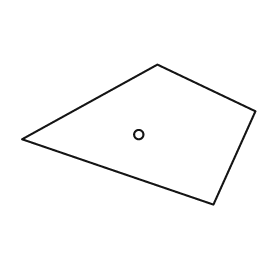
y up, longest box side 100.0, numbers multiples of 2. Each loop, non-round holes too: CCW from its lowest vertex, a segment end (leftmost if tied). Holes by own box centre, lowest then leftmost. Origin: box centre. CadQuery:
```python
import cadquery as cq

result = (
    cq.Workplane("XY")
    .moveTo(32.0, -30.0)
    .lineTo(50.0, 10.0)
    .lineTo(8.0, 30.0)
    .lineTo(-50.0, -2.0)
    .close()
    .moveTo(0.0, 0.0)
    .circle(2.0)
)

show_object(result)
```